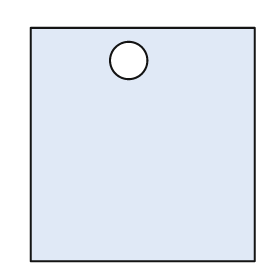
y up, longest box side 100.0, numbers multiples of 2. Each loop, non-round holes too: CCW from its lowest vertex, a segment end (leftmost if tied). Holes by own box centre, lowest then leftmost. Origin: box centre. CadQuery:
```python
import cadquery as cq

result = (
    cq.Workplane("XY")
    .moveTo(-48.0, -50.0)
    .lineTo(48.0, -50.0)
    .lineTo(48.0, 50.0)
    .lineTo(-48.0, 50.0)
    .close()
    .moveTo(-6.0, 36.0)
    .circle(8.0)
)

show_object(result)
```